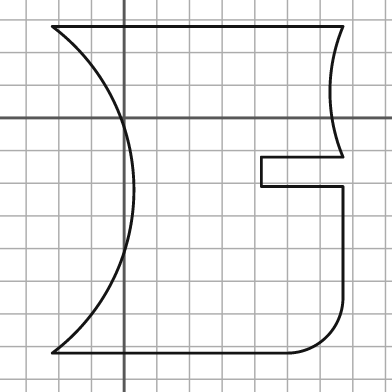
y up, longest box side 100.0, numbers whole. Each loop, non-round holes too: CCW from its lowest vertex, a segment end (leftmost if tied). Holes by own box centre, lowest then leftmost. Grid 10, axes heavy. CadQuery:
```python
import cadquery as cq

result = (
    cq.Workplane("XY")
    .moveTo(-22.0, -72.0)
    .lineTo(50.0, -72.0)
    .threePointArc((62.0, -67.0), (67.0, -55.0))
    .lineTo(67.0, -21.0)
    .lineTo(42.0, -21.0)
    .lineTo(42.0, -12.0)
    .lineTo(67.0, -12.0)
    .threePointArc((63.0, 8.0), (67.0, 28.0))
    .lineTo(-22.0, 28.0)
    .threePointArc((3.0, -22.0), (-22.0, -72.0))
    .close()
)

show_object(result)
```